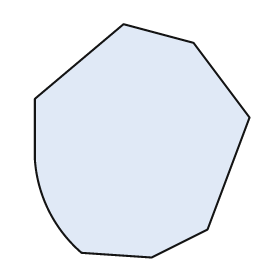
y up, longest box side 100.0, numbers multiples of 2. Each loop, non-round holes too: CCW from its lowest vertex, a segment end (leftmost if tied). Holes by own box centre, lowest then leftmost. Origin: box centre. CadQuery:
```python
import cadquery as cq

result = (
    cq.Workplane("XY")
    .moveTo(4.0, -50.0)
    .lineTo(28.0, -38.0)
    .lineTo(46.0, 10.0)
    .lineTo(22.0, 42.0)
    .lineTo(-8.0, 50.0)
    .lineTo(-46.0, 18.0)
    .lineTo(-46.0, -8.0)
    .threePointArc((-40.0, -30.0), (-26.0, -48.0))
    .close()
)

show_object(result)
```